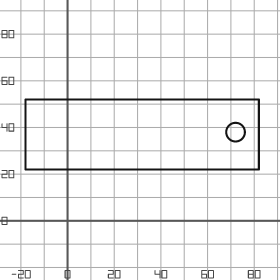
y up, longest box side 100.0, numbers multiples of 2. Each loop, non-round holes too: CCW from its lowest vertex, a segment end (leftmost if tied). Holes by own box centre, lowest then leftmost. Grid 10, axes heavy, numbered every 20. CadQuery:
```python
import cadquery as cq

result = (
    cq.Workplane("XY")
    .moveTo(-18.0, 22.0)
    .lineTo(82.0, 22.0)
    .lineTo(82.0, 52.0)
    .lineTo(-18.0, 52.0)
    .close()
    .moveTo(72.0, 38.0)
    .circle(4.0)
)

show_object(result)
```